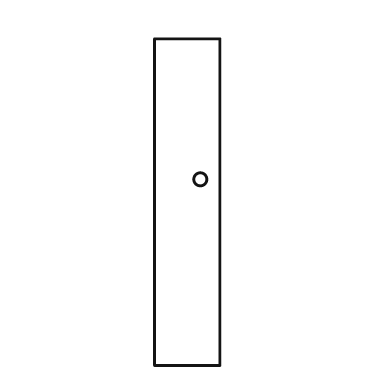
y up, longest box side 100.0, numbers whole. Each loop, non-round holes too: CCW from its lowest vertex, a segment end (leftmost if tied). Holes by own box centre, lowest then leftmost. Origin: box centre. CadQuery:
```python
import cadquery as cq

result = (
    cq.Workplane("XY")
    .moveTo(-10.0, -50.0)
    .lineTo(10.0, -50.0)
    .lineTo(10.0, 50.0)
    .lineTo(-10.0, 50.0)
    .close()
    .moveTo(4.0, 7.0)
    .circle(2.0)
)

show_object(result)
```